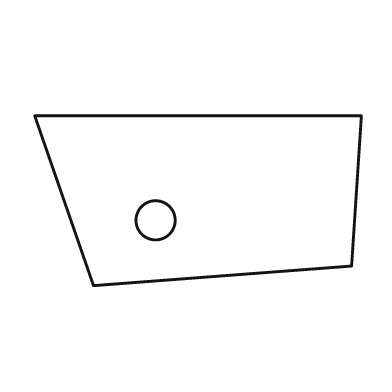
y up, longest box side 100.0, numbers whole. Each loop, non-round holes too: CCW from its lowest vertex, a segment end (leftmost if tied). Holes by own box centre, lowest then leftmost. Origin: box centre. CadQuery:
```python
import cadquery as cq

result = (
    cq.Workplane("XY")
    .moveTo(-32.0, -26.0)
    .lineTo(47.0, -20.0)
    .lineTo(50.0, 26.0)
    .lineTo(-50.0, 26.0)
    .close()
    .moveTo(-13.0, -6.0)
    .circle(6.0)
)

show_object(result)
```